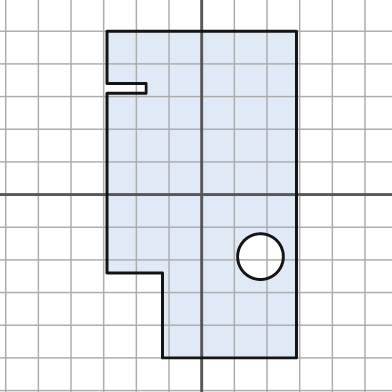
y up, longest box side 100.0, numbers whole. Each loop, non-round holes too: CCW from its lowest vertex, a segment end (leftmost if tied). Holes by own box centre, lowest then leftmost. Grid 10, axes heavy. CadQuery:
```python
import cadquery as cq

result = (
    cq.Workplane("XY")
    .moveTo(-12.0, -50.0)
    .lineTo(29.0, -50.0)
    .lineTo(29.0, 50.0)
    .lineTo(-29.0, 50.0)
    .lineTo(-29.0, 34.0)
    .lineTo(-17.0, 34.0)
    .lineTo(-17.0, 31.0)
    .lineTo(-29.0, 31.0)
    .lineTo(-29.0, -24.0)
    .lineTo(-12.0, -24.0)
    .close()
    .moveTo(18.0, -19.0)
    .circle(7.0)
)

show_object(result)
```